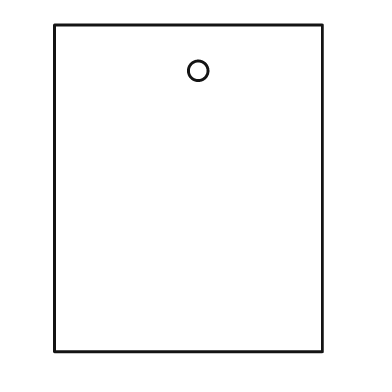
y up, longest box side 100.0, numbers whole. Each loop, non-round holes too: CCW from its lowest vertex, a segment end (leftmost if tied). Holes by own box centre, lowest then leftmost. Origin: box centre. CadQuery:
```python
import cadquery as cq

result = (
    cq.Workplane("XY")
    .moveTo(-41.0, -50.0)
    .lineTo(41.0, -50.0)
    .lineTo(41.0, 50.0)
    .lineTo(-41.0, 50.0)
    .close()
    .moveTo(3.0, 36.0)
    .circle(3.0)
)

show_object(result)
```